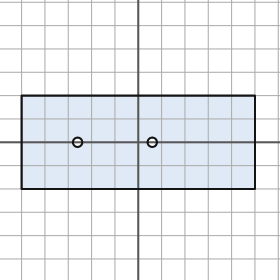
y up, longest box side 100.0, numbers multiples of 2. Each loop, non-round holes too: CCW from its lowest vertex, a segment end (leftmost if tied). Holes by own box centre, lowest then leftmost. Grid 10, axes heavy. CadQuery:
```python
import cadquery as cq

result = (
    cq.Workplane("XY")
    .moveTo(-50.0, -20.0)
    .lineTo(50.0, -20.0)
    .lineTo(50.0, 20.0)
    .lineTo(-50.0, 20.0)
    .close()
    .moveTo(-26.0, 0.0)
    .circle(2.0)
    .moveTo(6.0, 0.0)
    .circle(2.0)
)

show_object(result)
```